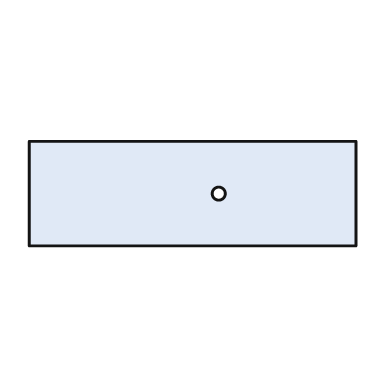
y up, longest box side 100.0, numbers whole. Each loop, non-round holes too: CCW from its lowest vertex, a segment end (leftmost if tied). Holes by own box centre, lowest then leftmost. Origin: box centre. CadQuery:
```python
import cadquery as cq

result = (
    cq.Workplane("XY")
    .moveTo(-50.0, -16.0)
    .lineTo(50.0, -16.0)
    .lineTo(50.0, 16.0)
    .lineTo(-50.0, 16.0)
    .close()
    .moveTo(8.0, 0.0)
    .circle(2.0)
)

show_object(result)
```